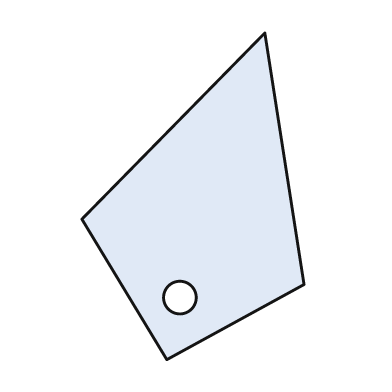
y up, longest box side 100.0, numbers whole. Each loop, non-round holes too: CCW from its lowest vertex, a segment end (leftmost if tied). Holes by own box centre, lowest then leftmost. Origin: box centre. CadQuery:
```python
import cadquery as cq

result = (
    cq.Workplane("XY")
    .moveTo(-8.0, -50.0)
    .lineTo(34.0, -27.0)
    .lineTo(22.0, 50.0)
    .lineTo(-34.0, -7.0)
    .close()
    .moveTo(-4.0, -31.0)
    .circle(5.0)
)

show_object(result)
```